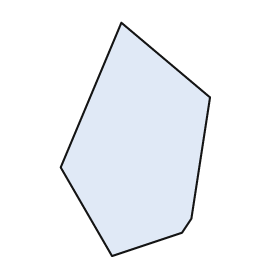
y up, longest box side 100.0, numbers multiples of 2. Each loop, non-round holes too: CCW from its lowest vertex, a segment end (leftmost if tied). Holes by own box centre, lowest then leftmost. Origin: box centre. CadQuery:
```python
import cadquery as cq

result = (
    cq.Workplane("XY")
    .moveTo(-10.0, -50.0)
    .lineTo(20.0, -40.0)
    .lineTo(24.0, -34.0)
    .lineTo(32.0, 18.0)
    .lineTo(-6.0, 50.0)
    .lineTo(-32.0, -12.0)
    .close()
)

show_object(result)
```